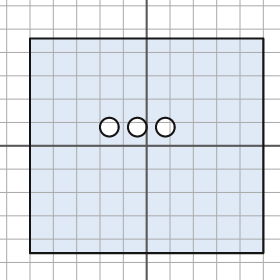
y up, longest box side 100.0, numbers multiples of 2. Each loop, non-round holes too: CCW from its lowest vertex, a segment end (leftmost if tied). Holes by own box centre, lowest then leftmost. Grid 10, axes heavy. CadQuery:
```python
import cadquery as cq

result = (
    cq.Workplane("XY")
    .moveTo(-50.0, -46.0)
    .lineTo(50.0, -46.0)
    .lineTo(50.0, 46.0)
    .lineTo(-50.0, 46.0)
    .close()
    .moveTo(-16.0, 8.0)
    .circle(4.0)
    .moveTo(-4.0, 8.0)
    .circle(4.0)
    .moveTo(8.0, 8.0)
    .circle(4.0)
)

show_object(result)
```